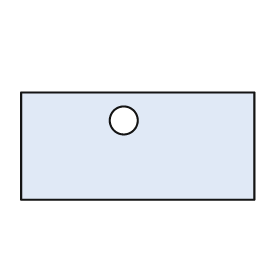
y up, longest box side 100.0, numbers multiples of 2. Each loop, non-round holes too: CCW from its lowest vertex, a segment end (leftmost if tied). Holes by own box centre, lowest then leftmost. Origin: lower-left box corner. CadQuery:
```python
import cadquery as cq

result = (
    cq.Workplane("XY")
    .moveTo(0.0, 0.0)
    .lineTo(100.0, 0.0)
    .lineTo(100.0, 46.0)
    .lineTo(0.0, 46.0)
    .close()
    .moveTo(44.0, 34.0)
    .circle(6.0)
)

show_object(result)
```